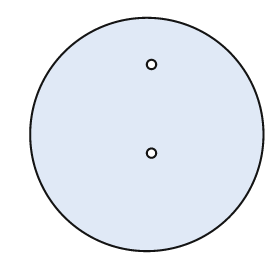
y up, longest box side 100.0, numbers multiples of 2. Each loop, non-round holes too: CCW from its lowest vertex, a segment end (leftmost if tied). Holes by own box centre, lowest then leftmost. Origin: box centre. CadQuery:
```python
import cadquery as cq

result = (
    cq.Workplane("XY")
    .moveTo(0.0, 0.0)
    .circle(50.0)
    .moveTo(2.0, -8.0)
    .circle(2.0)
    .moveTo(2.0, 30.0)
    .circle(2.0)
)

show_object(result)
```